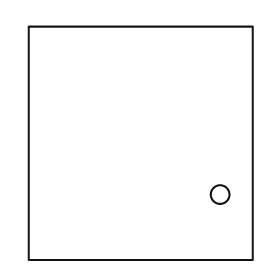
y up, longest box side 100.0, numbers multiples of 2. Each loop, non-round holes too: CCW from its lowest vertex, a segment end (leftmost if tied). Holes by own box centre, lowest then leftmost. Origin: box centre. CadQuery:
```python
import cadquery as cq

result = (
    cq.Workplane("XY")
    .moveTo(-48.0, -50.0)
    .lineTo(48.0, -50.0)
    .lineTo(48.0, 50.0)
    .lineTo(-48.0, 50.0)
    .close()
    .moveTo(34.0, -22.0)
    .circle(4.0)
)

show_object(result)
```